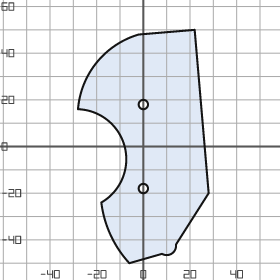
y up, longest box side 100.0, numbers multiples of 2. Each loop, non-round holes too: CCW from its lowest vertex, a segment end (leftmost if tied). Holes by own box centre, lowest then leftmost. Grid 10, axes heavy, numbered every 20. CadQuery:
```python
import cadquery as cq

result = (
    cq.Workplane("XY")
    .moveTo(-6.0, -50.0)
    .lineTo(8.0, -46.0)
    .threePointArc((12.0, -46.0), (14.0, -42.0))
    .lineTo(28.0, -20.0)
    .lineTo(22.0, 50.0)
    .lineTo(-2.0, 48.0)
    .threePointArc((-20.0, 36.0), (-28.0, 16.0))
    .threePointArc((-8.0, 0.0), (-18.0, -24.0))
    .threePointArc((-14.0, -38.0), (-6.0, -50.0))
    .close()
    .moveTo(0.0, -18.0)
    .circle(2.0)
    .moveTo(0.0, 18.0)
    .circle(2.0)
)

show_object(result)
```